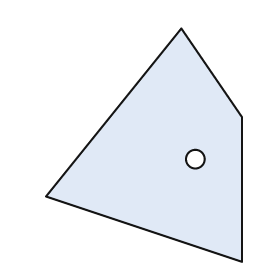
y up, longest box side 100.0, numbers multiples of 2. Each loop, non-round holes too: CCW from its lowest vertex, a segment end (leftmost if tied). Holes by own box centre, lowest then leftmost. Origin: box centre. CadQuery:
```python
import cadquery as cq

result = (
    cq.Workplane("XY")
    .moveTo(42.0, -50.0)
    .lineTo(42.0, 12.0)
    .lineTo(16.0, 50.0)
    .lineTo(-42.0, -22.0)
    .close()
    .moveTo(22.0, -6.0)
    .circle(4.0)
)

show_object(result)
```